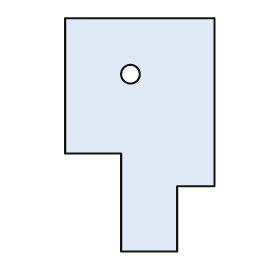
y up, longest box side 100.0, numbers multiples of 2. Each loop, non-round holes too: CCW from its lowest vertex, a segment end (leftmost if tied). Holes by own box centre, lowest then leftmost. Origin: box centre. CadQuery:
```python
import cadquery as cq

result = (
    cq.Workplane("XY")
    .moveTo(-8.0, -50.0)
    .lineTo(16.0, -50.0)
    .lineTo(16.0, -22.0)
    .lineTo(32.0, -22.0)
    .lineTo(32.0, 50.0)
    .lineTo(-32.0, 50.0)
    .lineTo(-32.0, -8.0)
    .lineTo(-8.0, -8.0)
    .close()
    .moveTo(-4.0, 26.0)
    .circle(4.0)
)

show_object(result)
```